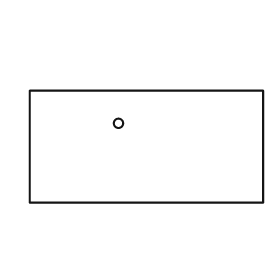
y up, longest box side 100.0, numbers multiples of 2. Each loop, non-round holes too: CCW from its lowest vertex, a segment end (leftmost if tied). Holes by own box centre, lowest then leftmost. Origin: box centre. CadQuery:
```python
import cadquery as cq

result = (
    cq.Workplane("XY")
    .moveTo(-50.0, -24.0)
    .lineTo(50.0, -24.0)
    .lineTo(50.0, 24.0)
    .lineTo(-50.0, 24.0)
    .close()
    .moveTo(-12.0, 10.0)
    .circle(2.0)
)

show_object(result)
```